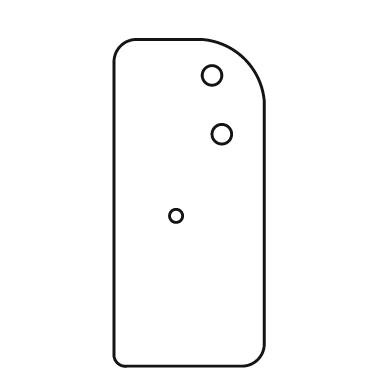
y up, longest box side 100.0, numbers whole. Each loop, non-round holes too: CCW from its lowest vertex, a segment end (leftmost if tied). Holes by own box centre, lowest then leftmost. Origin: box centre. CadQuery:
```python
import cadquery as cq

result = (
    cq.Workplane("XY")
    .moveTo(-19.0, -50.0)
    .lineTo(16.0, -50.0)
    .threePointArc((21.0, -48.0), (23.0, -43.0))
    .lineTo(23.0, 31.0)
    .threePointArc((17.0, 44.0), (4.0, 50.0))
    .lineTo(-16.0, 50.0)
    .threePointArc((-21.0, 48.0), (-23.0, 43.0))
    .lineTo(-23.0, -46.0)
    .threePointArc((-22.0, -49.0), (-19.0, -50.0))
    .close()
    .moveTo(-4.0, -4.0)
    .circle(2.0)
    .moveTo(10.0, 21.0)
    .circle(3.0)
    .moveTo(7.0, 39.0)
    .circle(3.0)
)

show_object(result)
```